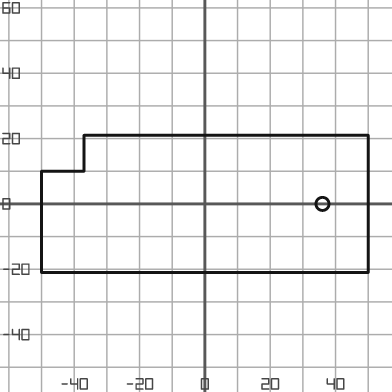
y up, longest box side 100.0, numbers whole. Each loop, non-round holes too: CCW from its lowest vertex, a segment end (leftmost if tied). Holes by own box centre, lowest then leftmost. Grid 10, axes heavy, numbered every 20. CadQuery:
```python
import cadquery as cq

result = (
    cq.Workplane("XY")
    .moveTo(-50.0, -21.0)
    .lineTo(50.0, -21.0)
    .lineTo(50.0, 21.0)
    .lineTo(-37.0, 21.0)
    .lineTo(-37.0, 10.0)
    .lineTo(-50.0, 10.0)
    .close()
    .moveTo(36.0, 0.0)
    .circle(2.0)
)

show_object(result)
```